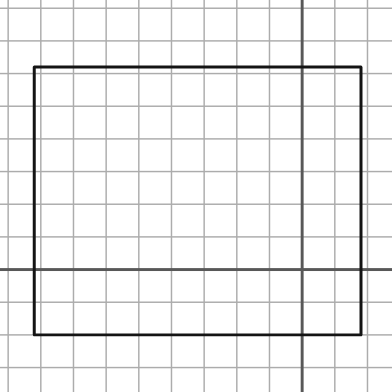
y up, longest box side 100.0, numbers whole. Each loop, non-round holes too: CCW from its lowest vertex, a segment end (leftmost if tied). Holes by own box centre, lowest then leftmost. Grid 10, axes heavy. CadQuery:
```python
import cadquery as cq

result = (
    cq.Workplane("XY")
    .moveTo(-82.0, -20.0)
    .lineTo(18.0, -20.0)
    .lineTo(18.0, 62.0)
    .lineTo(-82.0, 62.0)
    .close()
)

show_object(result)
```